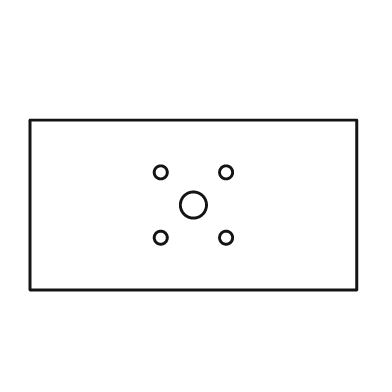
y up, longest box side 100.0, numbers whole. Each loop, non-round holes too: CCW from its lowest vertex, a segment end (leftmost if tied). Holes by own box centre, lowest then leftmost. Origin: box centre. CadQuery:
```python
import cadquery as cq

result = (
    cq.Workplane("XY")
    .moveTo(-50.0, -26.0)
    .lineTo(50.0, -26.0)
    .lineTo(50.0, 26.0)
    .lineTo(-50.0, 26.0)
    .close()
    .moveTo(-10.0, -10.0)
    .circle(2.0)
    .moveTo(10.0, -10.0)
    .circle(2.0)
    .moveTo(0.0, 0.0)
    .circle(4.0)
    .moveTo(-10.0, 10.0)
    .circle(2.0)
    .moveTo(10.0, 10.0)
    .circle(2.0)
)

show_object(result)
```